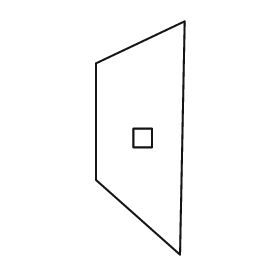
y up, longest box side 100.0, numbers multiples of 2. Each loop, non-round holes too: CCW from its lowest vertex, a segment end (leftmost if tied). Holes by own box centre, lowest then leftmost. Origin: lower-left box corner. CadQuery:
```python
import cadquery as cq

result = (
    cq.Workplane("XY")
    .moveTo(36.0, 0.0)
    .lineTo(38.0, 100.0)
    .lineTo(0.0, 82.0)
    .lineTo(0.0, 32.0)
    .close()
    .moveTo(16.0, 46.0)
    .lineTo(24.0, 46.0)
    .lineTo(24.0, 54.0)
    .lineTo(16.0, 54.0)
    .close()
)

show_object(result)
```